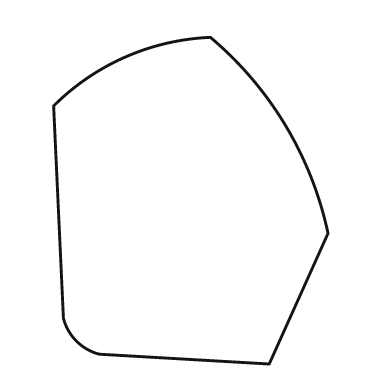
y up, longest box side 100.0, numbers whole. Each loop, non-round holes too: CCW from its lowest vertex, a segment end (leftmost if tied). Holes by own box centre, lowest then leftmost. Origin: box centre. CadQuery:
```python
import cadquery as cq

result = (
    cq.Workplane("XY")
    .moveTo(24.0, -50.0)
    .lineTo(42.0, -10.0)
    .threePointArc((29.0, 23.0), (6.0, 50.0))
    .threePointArc((-20.0, 44.0), (-42.0, 29.0))
    .lineTo(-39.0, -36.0)
    .threePointArc((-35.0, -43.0), (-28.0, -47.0))
    .close()
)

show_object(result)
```